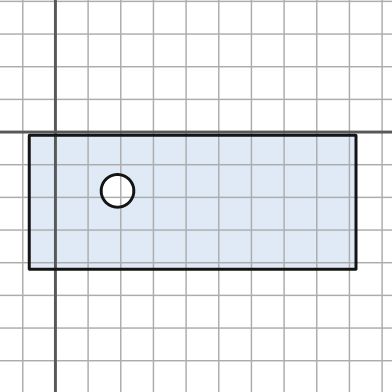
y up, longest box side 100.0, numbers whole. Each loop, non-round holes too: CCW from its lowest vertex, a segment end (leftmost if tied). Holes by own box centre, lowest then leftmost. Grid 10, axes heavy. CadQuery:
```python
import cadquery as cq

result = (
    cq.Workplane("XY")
    .moveTo(-8.0, -42.0)
    .lineTo(92.0, -42.0)
    .lineTo(92.0, -1.0)
    .lineTo(-8.0, -1.0)
    .close()
    .moveTo(19.0, -18.0)
    .circle(5.0)
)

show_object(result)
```